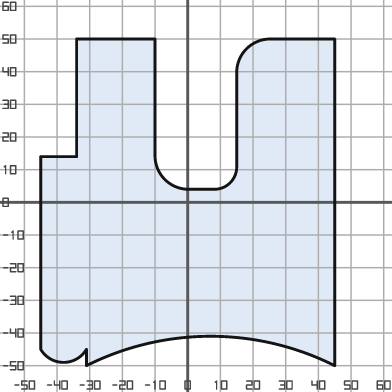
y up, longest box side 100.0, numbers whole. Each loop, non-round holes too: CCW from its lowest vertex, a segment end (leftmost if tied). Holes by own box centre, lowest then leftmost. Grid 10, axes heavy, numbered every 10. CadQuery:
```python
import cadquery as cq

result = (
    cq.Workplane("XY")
    .moveTo(-31.0, -50.0)
    .threePointArc((7.0, -41.0), (45.0, -50.0))
    .lineTo(45.0, 50.0)
    .lineTo(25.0, 50.0)
    .threePointArc((18.0, 47.0), (15.0, 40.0))
    .lineTo(15.0, 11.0)
    .threePointArc((13.0, 6.0), (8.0, 4.0))
    .lineTo(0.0, 4.0)
    .threePointArc((-7.0, 7.0), (-10.0, 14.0))
    .lineTo(-10.0, 50.0)
    .lineTo(-34.0, 50.0)
    .lineTo(-34.0, 14.0)
    .lineTo(-45.0, 14.0)
    .lineTo(-45.0, -45.0)
    .threePointArc((-38.0, -49.0), (-31.0, -45.0))
    .close()
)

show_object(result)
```